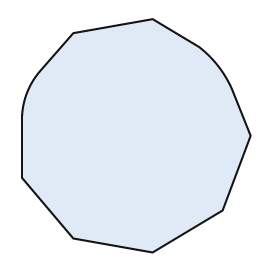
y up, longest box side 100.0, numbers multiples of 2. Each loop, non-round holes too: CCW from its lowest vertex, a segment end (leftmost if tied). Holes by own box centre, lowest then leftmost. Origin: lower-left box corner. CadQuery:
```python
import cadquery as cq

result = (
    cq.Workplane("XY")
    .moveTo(56.0, 0.0)
    .lineTo(86.0, 18.0)
    .lineTo(98.0, 50.0)
    .lineTo(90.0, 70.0)
    .threePointArc((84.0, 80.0), (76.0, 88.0))
    .lineTo(56.0, 100.0)
    .lineTo(22.0, 94.0)
    .lineTo(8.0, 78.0)
    .threePointArc((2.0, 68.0), (0.0, 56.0))
    .lineTo(0.0, 32.0)
    .lineTo(22.0, 6.0)
    .close()
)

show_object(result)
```